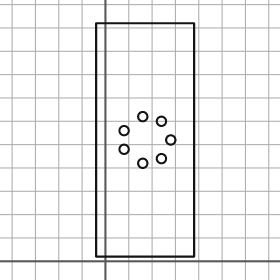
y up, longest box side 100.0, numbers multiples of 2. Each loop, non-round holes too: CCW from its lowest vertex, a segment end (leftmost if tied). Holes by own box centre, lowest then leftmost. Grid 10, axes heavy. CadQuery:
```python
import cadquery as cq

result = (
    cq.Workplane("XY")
    .moveTo(-4.0, 2.0)
    .lineTo(38.0, 2.0)
    .lineTo(38.0, 102.0)
    .lineTo(-4.0, 102.0)
    .close()
    .moveTo(16.0, 42.0)
    .circle(2.0)
    .moveTo(24.0, 44.0)
    .circle(2.0)
    .moveTo(8.0, 48.0)
    .circle(2.0)
    .moveTo(28.0, 52.0)
    .circle(2.0)
    .moveTo(8.0, 56.0)
    .circle(2.0)
    .moveTo(24.0, 60.0)
    .circle(2.0)
    .moveTo(16.0, 62.0)
    .circle(2.0)
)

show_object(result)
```